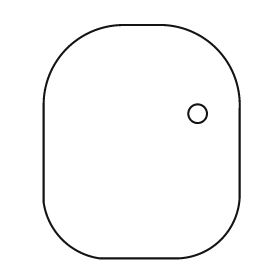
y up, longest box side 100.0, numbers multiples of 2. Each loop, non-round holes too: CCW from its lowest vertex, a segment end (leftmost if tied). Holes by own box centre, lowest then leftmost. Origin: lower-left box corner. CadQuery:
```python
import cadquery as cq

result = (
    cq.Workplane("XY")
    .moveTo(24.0, 0.0)
    .lineTo(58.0, 0.0)
    .threePointArc((76.0, 8.0), (84.0, 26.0))
    .lineTo(84.0, 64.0)
    .threePointArc((74.0, 90.0), (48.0, 100.0))
    .lineTo(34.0, 100.0)
    .threePointArc((10.0, 90.0), (0.0, 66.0))
    .lineTo(0.0, 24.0)
    .threePointArc((8.0, 8.0), (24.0, 0.0))
    .close()
    .moveTo(66.0, 62.0)
    .circle(4.0)
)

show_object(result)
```